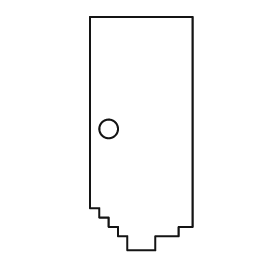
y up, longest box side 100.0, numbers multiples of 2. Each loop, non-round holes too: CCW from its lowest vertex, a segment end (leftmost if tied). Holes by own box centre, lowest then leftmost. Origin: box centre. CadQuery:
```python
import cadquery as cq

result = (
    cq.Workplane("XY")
    .moveTo(-6.0, -50.0)
    .lineTo(6.0, -50.0)
    .lineTo(6.0, -44.0)
    .lineTo(16.0, -44.0)
    .lineTo(16.0, -40.0)
    .lineTo(22.0, -40.0)
    .lineTo(22.0, 50.0)
    .lineTo(-22.0, 50.0)
    .lineTo(-22.0, -32.0)
    .lineTo(-18.0, -32.0)
    .lineTo(-18.0, -36.0)
    .lineTo(-14.0, -36.0)
    .lineTo(-14.0, -40.0)
    .lineTo(-10.0, -40.0)
    .lineTo(-10.0, -44.0)
    .lineTo(-6.0, -44.0)
    .close()
    .moveTo(-14.0, 2.0)
    .circle(4.0)
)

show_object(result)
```